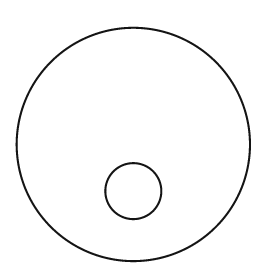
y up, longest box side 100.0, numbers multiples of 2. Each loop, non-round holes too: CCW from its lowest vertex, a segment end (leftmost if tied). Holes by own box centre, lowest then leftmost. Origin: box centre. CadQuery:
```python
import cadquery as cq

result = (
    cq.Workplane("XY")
    .moveTo(0.0, 0.0)
    .circle(50.0)
    .moveTo(0.0, -20.0)
    .circle(12.0)
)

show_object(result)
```